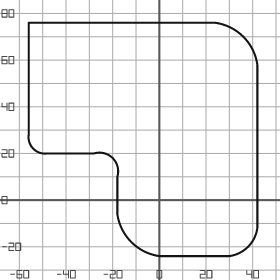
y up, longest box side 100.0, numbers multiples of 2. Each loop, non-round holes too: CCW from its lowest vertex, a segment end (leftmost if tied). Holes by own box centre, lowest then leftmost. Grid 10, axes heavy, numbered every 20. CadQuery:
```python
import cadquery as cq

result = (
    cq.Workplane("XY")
    .moveTo(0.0, -24.0)
    .lineTo(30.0, -24.0)
    .threePointArc((38.0, -20.0), (42.0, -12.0))
    .lineTo(42.0, 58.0)
    .threePointArc((36.0, 70.0), (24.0, 76.0))
    .lineTo(-56.0, 76.0)
    .lineTo(-56.0, 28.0)
    .threePointArc((-54.0, 22.0), (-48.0, 20.0))
    .lineTo(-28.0, 20.0)
    .threePointArc((-20.0, 18.0), (-18.0, 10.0))
    .lineTo(-18.0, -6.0)
    .threePointArc((-12.0, -18.0), (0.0, -24.0))
    .close()
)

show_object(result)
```